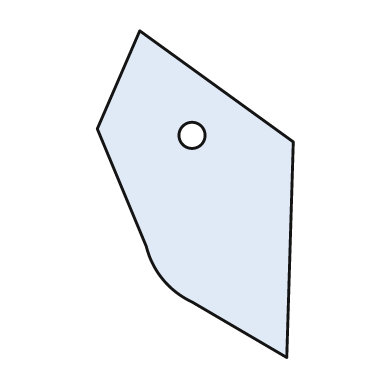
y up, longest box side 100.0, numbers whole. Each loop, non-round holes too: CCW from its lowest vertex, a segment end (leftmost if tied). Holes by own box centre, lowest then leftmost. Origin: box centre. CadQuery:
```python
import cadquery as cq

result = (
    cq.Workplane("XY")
    .moveTo(28.0, -50.0)
    .lineTo(30.0, 16.0)
    .lineTo(-17.0, 50.0)
    .lineTo(-30.0, 20.0)
    .lineTo(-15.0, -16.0)
    .threePointArc((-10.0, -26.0), (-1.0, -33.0))
    .close()
    .moveTo(-1.0, 18.0)
    .circle(4.0)
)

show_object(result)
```